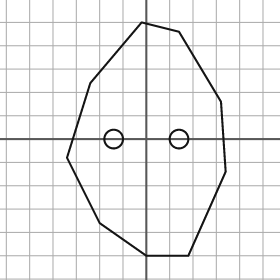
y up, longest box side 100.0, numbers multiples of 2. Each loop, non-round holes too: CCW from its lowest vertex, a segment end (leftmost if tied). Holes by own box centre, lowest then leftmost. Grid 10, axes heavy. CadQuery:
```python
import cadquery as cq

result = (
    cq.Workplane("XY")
    .moveTo(0.0, -50.0)
    .lineTo(18.0, -50.0)
    .lineTo(34.0, -14.0)
    .lineTo(32.0, 16.0)
    .lineTo(14.0, 46.0)
    .lineTo(-2.0, 50.0)
    .lineTo(-24.0, 24.0)
    .lineTo(-34.0, -8.0)
    .lineTo(-20.0, -36.0)
    .close()
    .moveTo(-14.0, 0.0)
    .circle(4.0)
    .moveTo(14.0, 0.0)
    .circle(4.0)
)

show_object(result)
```